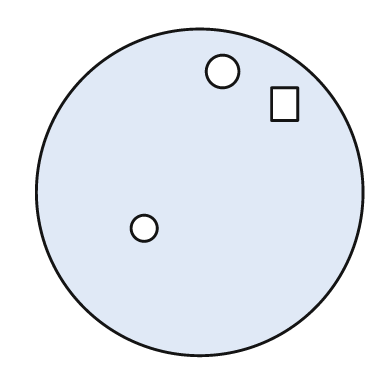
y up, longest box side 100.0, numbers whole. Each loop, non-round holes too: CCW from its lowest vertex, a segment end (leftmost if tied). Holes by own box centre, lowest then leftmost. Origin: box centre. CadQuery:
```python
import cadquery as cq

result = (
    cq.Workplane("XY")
    .moveTo(0.0, 0.0)
    .circle(50.0)
    .moveTo(-17.0, -11.0)
    .circle(4.0)
    .moveTo(22.0, 22.0)
    .lineTo(30.0, 22.0)
    .lineTo(30.0, 32.0)
    .lineTo(22.0, 32.0)
    .close()
    .moveTo(7.0, 37.0)
    .circle(5.0)
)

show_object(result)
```